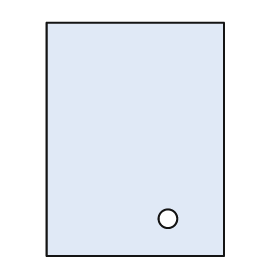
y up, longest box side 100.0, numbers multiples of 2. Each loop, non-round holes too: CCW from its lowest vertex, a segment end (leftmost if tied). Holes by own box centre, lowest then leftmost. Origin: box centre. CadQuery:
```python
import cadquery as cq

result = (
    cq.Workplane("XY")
    .moveTo(-38.0, -50.0)
    .lineTo(38.0, -50.0)
    .lineTo(38.0, 50.0)
    .lineTo(-38.0, 50.0)
    .close()
    .moveTo(14.0, -34.0)
    .circle(4.0)
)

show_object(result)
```